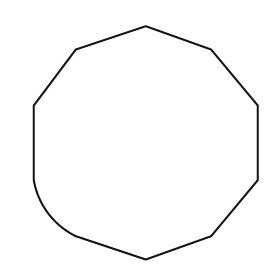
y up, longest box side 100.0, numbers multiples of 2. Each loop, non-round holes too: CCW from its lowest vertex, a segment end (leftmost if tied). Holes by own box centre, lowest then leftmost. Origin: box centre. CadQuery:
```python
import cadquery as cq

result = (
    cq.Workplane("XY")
    .moveTo(0.0, -50.0)
    .lineTo(28.0, -40.0)
    .lineTo(48.0, -16.0)
    .lineTo(48.0, 16.0)
    .lineTo(28.0, 40.0)
    .lineTo(0.0, 50.0)
    .lineTo(-30.0, 40.0)
    .lineTo(-48.0, 16.0)
    .lineTo(-48.0, -16.0)
    .threePointArc((-42.0, -30.0), (-30.0, -40.0))
    .close()
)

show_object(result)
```